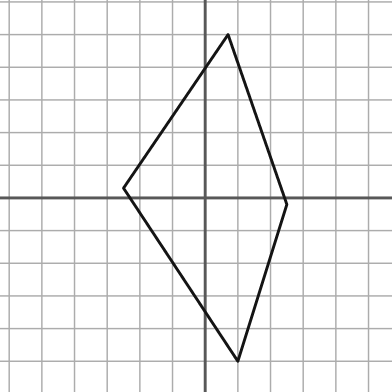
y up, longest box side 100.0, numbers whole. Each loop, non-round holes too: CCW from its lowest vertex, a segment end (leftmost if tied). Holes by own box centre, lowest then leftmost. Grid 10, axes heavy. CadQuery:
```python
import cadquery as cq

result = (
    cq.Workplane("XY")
    .moveTo(10.0, -50.0)
    .lineTo(25.0, -2.0)
    .lineTo(7.0, 50.0)
    .lineTo(-25.0, 3.0)
    .close()
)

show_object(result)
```